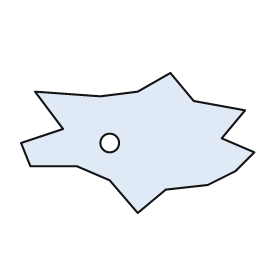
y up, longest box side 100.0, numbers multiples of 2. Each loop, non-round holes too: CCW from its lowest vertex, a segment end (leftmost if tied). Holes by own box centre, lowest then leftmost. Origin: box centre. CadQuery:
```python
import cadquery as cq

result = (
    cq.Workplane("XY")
    .moveTo(0.0, -30.0)
    .lineTo(12.0, -20.0)
    .lineTo(30.0, -18.0)
    .lineTo(42.0, -12.0)
    .lineTo(50.0, -4.0)
    .lineTo(36.0, 2.0)
    .lineTo(46.0, 14.0)
    .lineTo(24.0, 18.0)
    .lineTo(14.0, 30.0)
    .lineTo(0.0, 22.0)
    .lineTo(-16.0, 20.0)
    .lineTo(-44.0, 22.0)
    .lineTo(-32.0, 6.0)
    .lineTo(-50.0, 0.0)
    .lineTo(-46.0, -10.0)
    .lineTo(-26.0, -10.0)
    .lineTo(-12.0, -16.0)
    .close()
    .moveTo(-12.0, 0.0)
    .circle(4.0)
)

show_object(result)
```